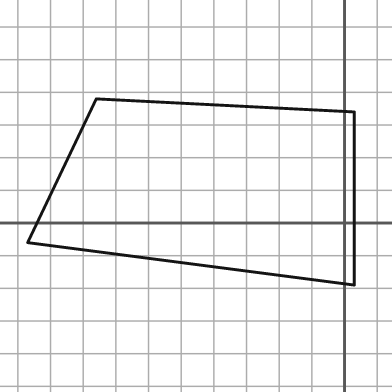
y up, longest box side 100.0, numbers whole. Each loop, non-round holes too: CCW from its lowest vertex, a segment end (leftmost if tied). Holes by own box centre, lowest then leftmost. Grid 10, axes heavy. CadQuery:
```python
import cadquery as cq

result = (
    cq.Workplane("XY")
    .moveTo(3.0, -19.0)
    .lineTo(3.0, 34.0)
    .lineTo(-76.0, 38.0)
    .lineTo(-97.0, -6.0)
    .close()
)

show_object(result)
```